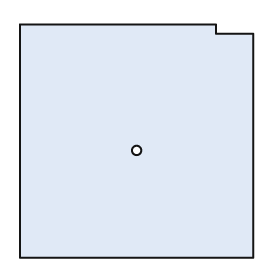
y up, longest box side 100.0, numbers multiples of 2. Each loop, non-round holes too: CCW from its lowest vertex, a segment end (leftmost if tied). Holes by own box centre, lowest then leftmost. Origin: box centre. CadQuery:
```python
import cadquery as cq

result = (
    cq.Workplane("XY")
    .moveTo(-50.0, -50.0)
    .lineTo(50.0, -50.0)
    .lineTo(50.0, 46.0)
    .lineTo(34.0, 46.0)
    .lineTo(34.0, 50.0)
    .lineTo(-50.0, 50.0)
    .close()
    .moveTo(0.0, -4.0)
    .circle(2.0)
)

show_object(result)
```